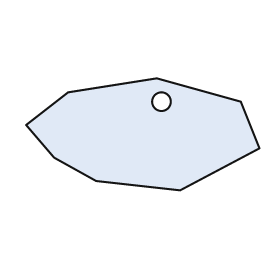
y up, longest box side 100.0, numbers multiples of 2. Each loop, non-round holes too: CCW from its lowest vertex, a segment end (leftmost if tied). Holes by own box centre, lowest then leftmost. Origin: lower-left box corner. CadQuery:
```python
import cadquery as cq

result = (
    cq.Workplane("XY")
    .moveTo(66.0, 0.0)
    .lineTo(100.0, 18.0)
    .lineTo(92.0, 38.0)
    .lineTo(56.0, 48.0)
    .lineTo(18.0, 42.0)
    .lineTo(0.0, 28.0)
    .lineTo(12.0, 14.0)
    .lineTo(30.0, 4.0)
    .close()
    .moveTo(58.0, 38.0)
    .circle(4.0)
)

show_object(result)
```